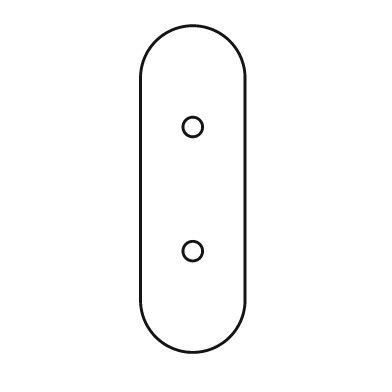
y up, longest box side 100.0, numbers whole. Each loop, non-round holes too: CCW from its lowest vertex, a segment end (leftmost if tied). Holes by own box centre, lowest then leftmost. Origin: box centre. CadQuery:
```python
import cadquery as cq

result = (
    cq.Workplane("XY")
    .moveTo(-16.0, -34.0)
    .threePointArc((0.0, -50.0), (16.0, -34.0))
    .lineTo(16.0, 34.0)
    .threePointArc((0.0, 50.0), (-16.0, 34.0))
    .close()
    .moveTo(0.0, -19.0)
    .circle(3.0)
    .moveTo(0.0, 19.0)
    .circle(3.0)
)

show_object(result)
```